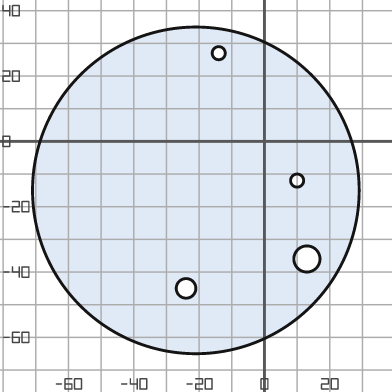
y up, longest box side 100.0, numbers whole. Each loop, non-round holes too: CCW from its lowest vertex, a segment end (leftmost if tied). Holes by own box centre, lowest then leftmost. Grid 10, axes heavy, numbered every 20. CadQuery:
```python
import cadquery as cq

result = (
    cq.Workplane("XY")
    .moveTo(-21.0, -15.0)
    .circle(50.0)
    .moveTo(-24.0, -45.0)
    .circle(3.0)
    .moveTo(13.0, -36.0)
    .circle(4.0)
    .moveTo(10.0, -12.0)
    .circle(2.0)
    .moveTo(-14.0, 27.0)
    .circle(2.0)
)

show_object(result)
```